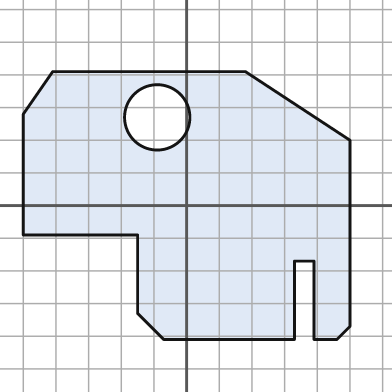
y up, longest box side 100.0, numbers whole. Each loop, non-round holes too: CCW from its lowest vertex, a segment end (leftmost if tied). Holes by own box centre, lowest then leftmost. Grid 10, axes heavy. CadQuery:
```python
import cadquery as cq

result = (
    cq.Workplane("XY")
    .moveTo(-7.0, -41.0)
    .lineTo(33.0, -41.0)
    .lineTo(33.0, -17.0)
    .lineTo(39.0, -17.0)
    .lineTo(39.0, -41.0)
    .lineTo(46.0, -41.0)
    .lineTo(50.0, -37.0)
    .lineTo(50.0, 20.0)
    .lineTo(18.0, 41.0)
    .lineTo(-41.0, 41.0)
    .lineTo(-50.0, 28.0)
    .lineTo(-50.0, -9.0)
    .lineTo(-15.0, -9.0)
    .lineTo(-15.0, -33.0)
    .close()
    .moveTo(-9.0, 27.0)
    .circle(10.0)
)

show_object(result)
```